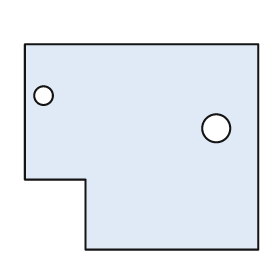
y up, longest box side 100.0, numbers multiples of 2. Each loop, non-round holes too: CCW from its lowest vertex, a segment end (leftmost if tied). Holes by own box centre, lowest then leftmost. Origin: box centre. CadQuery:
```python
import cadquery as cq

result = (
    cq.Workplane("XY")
    .moveTo(-24.0, -44.0)
    .lineTo(50.0, -44.0)
    .lineTo(50.0, 44.0)
    .lineTo(-50.0, 44.0)
    .lineTo(-50.0, -14.0)
    .lineTo(-24.0, -14.0)
    .close()
    .moveTo(32.0, 8.0)
    .circle(6.0)
    .moveTo(-42.0, 22.0)
    .circle(4.0)
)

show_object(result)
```